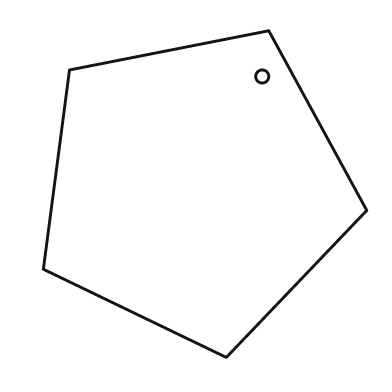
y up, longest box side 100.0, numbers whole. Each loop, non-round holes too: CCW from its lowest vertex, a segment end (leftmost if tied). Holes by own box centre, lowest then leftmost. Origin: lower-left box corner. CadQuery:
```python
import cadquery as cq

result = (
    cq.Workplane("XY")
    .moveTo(56.0, 0.0)
    .lineTo(99.0, 45.0)
    .lineTo(69.0, 100.0)
    .lineTo(8.0, 88.0)
    .lineTo(0.0, 27.0)
    .close()
    .moveTo(67.0, 86.0)
    .circle(2.0)
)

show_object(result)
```